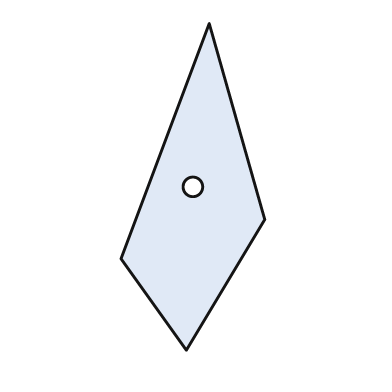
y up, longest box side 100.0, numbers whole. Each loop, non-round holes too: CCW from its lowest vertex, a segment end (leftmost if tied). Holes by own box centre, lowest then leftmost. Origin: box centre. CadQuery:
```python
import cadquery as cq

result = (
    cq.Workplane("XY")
    .moveTo(-2.0, -50.0)
    .lineTo(22.0, -10.0)
    .lineTo(5.0, 50.0)
    .lineTo(-22.0, -22.0)
    .close()
    .moveTo(0.0, 0.0)
    .circle(3.0)
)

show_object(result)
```